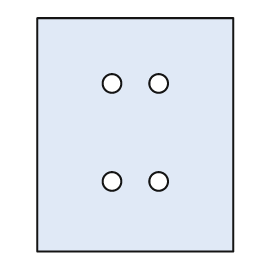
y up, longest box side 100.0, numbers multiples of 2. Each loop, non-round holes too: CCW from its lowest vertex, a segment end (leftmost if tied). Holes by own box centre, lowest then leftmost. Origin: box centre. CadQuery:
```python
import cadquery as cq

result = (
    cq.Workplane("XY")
    .moveTo(-42.0, -50.0)
    .lineTo(42.0, -50.0)
    .lineTo(42.0, 50.0)
    .lineTo(-42.0, 50.0)
    .close()
    .moveTo(-10.0, -20.0)
    .circle(4.0)
    .moveTo(10.0, -20.0)
    .circle(4.0)
    .moveTo(-10.0, 22.0)
    .circle(4.0)
    .moveTo(10.0, 22.0)
    .circle(4.0)
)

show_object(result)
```